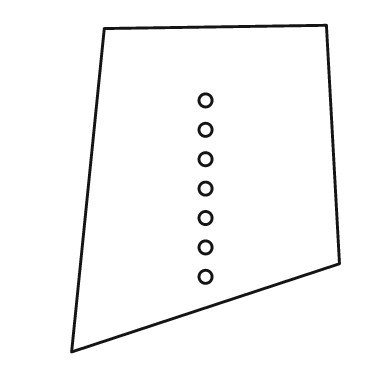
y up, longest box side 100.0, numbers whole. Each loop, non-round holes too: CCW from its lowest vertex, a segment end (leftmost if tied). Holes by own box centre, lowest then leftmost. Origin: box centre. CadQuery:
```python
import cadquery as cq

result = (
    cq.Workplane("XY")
    .moveTo(-41.0, -50.0)
    .lineTo(41.0, -23.0)
    .lineTo(37.0, 50.0)
    .lineTo(-31.0, 49.0)
    .close()
    .moveTo(0.0, -27.0)
    .circle(2.0)
    .moveTo(0.0, -18.0)
    .circle(2.0)
    .moveTo(0.0, -9.0)
    .circle(2.0)
    .moveTo(0.0, 0.0)
    .circle(2.0)
    .moveTo(0.0, 9.0)
    .circle(2.0)
    .moveTo(0.0, 18.0)
    .circle(2.0)
    .moveTo(0.0, 27.0)
    .circle(2.0)
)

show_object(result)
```